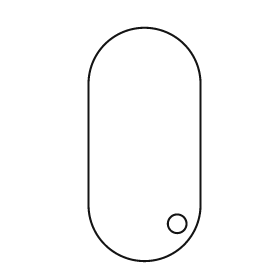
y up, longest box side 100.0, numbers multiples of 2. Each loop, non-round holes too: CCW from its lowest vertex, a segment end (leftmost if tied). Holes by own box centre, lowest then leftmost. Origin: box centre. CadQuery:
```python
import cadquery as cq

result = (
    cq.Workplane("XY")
    .moveTo(-24.0, -26.0)
    .threePointArc((0.0, -50.0), (24.0, -26.0))
    .lineTo(24.0, 26.0)
    .threePointArc((0.0, 50.0), (-24.0, 26.0))
    .close()
    .moveTo(14.0, -34.0)
    .circle(4.0)
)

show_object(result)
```